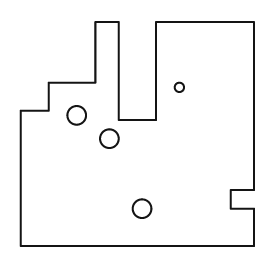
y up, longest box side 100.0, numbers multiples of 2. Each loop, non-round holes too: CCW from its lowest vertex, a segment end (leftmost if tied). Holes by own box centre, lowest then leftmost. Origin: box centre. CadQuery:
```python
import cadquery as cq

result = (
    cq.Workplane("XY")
    .moveTo(-50.0, -48.0)
    .lineTo(50.0, -48.0)
    .lineTo(50.0, -32.0)
    .lineTo(40.0, -32.0)
    .lineTo(40.0, -24.0)
    .lineTo(50.0, -24.0)
    .lineTo(50.0, 48.0)
    .lineTo(8.0, 48.0)
    .lineTo(8.0, 6.0)
    .lineTo(-8.0, 6.0)
    .lineTo(-8.0, 48.0)
    .lineTo(-18.0, 48.0)
    .lineTo(-18.0, 22.0)
    .lineTo(-38.0, 22.0)
    .lineTo(-38.0, 10.0)
    .lineTo(-50.0, 10.0)
    .close()
    .moveTo(2.0, -32.0)
    .circle(4.0)
    .moveTo(-12.0, -2.0)
    .circle(4.0)
    .moveTo(-26.0, 8.0)
    .circle(4.0)
    .moveTo(18.0, 20.0)
    .circle(2.0)
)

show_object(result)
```